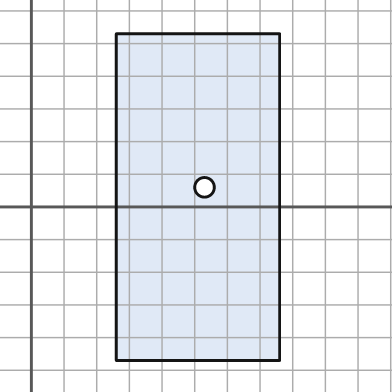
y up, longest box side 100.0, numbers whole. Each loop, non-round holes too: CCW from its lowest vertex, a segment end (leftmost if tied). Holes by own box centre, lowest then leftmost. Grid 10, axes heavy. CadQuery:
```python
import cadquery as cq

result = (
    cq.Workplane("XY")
    .moveTo(26.0, -47.0)
    .lineTo(76.0, -47.0)
    .lineTo(76.0, 53.0)
    .lineTo(26.0, 53.0)
    .close()
    .moveTo(53.0, 6.0)
    .circle(3.0)
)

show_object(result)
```